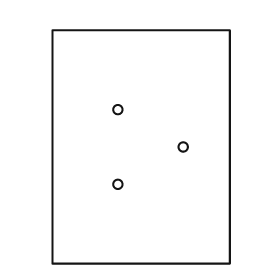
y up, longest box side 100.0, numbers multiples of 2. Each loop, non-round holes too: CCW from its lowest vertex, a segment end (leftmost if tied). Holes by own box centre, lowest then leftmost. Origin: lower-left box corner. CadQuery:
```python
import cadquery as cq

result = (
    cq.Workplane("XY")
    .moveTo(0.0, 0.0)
    .lineTo(76.0, 0.0)
    .lineTo(76.0, 100.0)
    .lineTo(0.0, 100.0)
    .close()
    .moveTo(28.0, 34.0)
    .circle(2.0)
    .moveTo(56.0, 50.0)
    .circle(2.0)
    .moveTo(28.0, 66.0)
    .circle(2.0)
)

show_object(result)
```